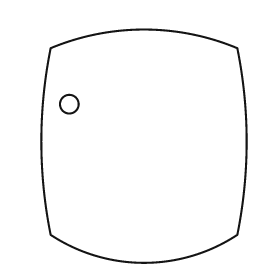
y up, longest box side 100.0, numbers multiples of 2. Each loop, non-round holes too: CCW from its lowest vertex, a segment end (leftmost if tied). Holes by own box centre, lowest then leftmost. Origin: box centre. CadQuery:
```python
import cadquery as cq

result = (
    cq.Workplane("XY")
    .moveTo(-40.0, -38.0)
    .threePointArc((0.0, -50.0), (40.0, -38.0))
    .threePointArc((44.0, 2.0), (40.0, 42.0))
    .threePointArc((0.0, 50.0), (-40.0, 42.0))
    .threePointArc((-44.0, 2.0), (-40.0, -38.0))
    .close()
    .moveTo(-32.0, 18.0)
    .circle(4.0)
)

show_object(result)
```